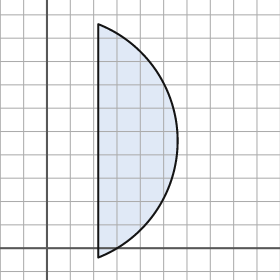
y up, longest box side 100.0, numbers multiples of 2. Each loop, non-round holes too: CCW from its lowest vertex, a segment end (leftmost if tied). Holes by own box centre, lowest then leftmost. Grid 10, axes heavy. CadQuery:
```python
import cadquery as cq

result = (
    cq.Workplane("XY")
    .moveTo(22.0, -4.0)
    .threePointArc((56.0, 46.0), (22.0, 96.0))
    .close()
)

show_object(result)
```